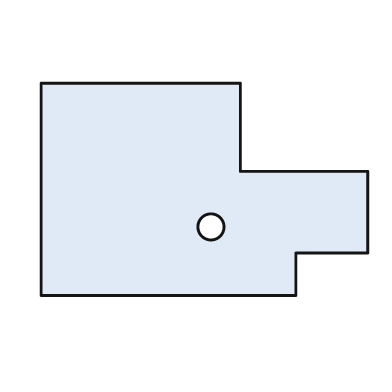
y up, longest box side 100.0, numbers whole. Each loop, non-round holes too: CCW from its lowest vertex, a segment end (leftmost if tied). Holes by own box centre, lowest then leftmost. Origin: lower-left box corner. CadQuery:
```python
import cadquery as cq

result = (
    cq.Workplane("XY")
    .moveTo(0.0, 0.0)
    .lineTo(78.0, 0.0)
    .lineTo(78.0, 13.0)
    .lineTo(100.0, 13.0)
    .lineTo(100.0, 38.0)
    .lineTo(61.0, 38.0)
    .lineTo(61.0, 65.0)
    .lineTo(0.0, 65.0)
    .close()
    .moveTo(52.0, 21.0)
    .circle(4.0)
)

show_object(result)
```